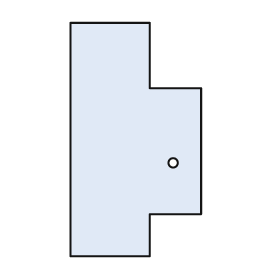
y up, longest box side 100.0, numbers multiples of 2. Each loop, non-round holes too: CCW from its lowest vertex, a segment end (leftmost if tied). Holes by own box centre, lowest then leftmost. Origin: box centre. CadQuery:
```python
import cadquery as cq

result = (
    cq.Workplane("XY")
    .moveTo(-28.0, -50.0)
    .lineTo(6.0, -50.0)
    .lineTo(6.0, -32.0)
    .lineTo(28.0, -32.0)
    .lineTo(28.0, 22.0)
    .lineTo(6.0, 22.0)
    .lineTo(6.0, 50.0)
    .lineTo(-28.0, 50.0)
    .close()
    .moveTo(16.0, -10.0)
    .circle(2.0)
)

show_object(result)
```